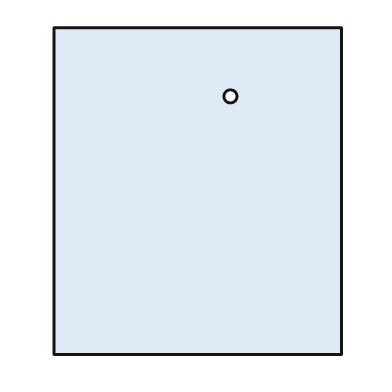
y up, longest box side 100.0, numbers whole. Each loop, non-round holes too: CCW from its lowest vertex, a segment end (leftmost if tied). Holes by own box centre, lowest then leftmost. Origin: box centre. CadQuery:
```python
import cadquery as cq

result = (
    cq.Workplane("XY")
    .moveTo(-44.0, -50.0)
    .lineTo(44.0, -50.0)
    .lineTo(44.0, 50.0)
    .lineTo(-44.0, 50.0)
    .close()
    .moveTo(10.0, 29.0)
    .circle(2.0)
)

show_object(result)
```